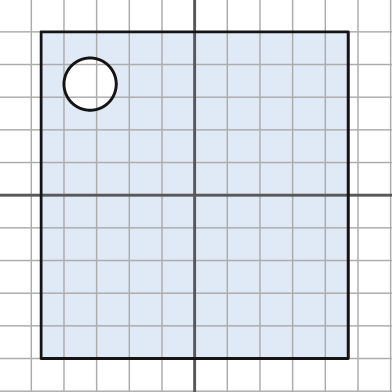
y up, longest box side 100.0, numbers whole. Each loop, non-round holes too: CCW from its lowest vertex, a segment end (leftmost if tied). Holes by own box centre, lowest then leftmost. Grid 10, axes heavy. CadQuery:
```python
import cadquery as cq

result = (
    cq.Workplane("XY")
    .moveTo(-47.0, -50.0)
    .lineTo(47.0, -50.0)
    .lineTo(47.0, 50.0)
    .lineTo(-47.0, 50.0)
    .close()
    .moveTo(-32.0, 34.0)
    .circle(8.0)
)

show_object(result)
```